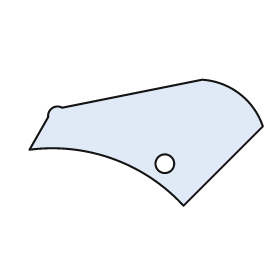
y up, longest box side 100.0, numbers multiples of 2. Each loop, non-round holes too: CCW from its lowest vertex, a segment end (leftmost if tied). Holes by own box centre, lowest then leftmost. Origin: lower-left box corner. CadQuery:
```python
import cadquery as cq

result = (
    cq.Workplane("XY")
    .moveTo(66.0, 0.0)
    .lineTo(100.0, 34.0)
    .threePointArc((90.0, 48.0), (74.0, 54.0))
    .lineTo(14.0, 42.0)
    .threePointArc((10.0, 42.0), (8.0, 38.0))
    .lineTo(0.0, 24.0)
    .threePointArc((36.0, 20.0), (66.0, 0.0))
    .close()
    .moveTo(58.0, 18.0)
    .circle(4.0)
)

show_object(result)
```